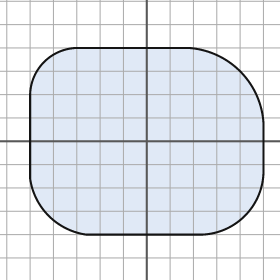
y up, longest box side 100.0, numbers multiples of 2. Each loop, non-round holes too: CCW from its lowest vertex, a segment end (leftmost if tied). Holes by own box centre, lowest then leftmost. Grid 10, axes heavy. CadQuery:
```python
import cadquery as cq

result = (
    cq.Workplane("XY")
    .moveTo(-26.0, -40.0)
    .lineTo(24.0, -40.0)
    .threePointArc((42.0, -32.0), (50.0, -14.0))
    .lineTo(50.0, 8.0)
    .threePointArc((40.0, 30.0), (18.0, 40.0))
    .lineTo(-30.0, 40.0)
    .threePointArc((-44.0, 34.0), (-50.0, 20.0))
    .lineTo(-50.0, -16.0)
    .threePointArc((-42.0, -32.0), (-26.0, -40.0))
    .close()
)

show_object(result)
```